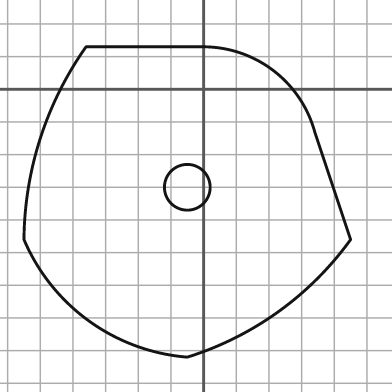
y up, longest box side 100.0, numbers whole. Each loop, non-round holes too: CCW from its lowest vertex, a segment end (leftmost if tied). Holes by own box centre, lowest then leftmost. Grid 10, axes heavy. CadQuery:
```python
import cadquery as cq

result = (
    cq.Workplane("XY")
    .moveTo(-5.0, -82.0)
    .threePointArc((23.0, -68.0), (45.0, -46.0))
    .lineTo(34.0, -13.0)
    .threePointArc((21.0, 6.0), (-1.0, 13.0))
    .lineTo(-36.0, 13.0)
    .threePointArc((-50.0, -15.0), (-55.0, -46.0))
    .threePointArc((-35.0, -71.0), (-5.0, -82.0))
    .close()
    .moveTo(-5.0, -30.0)
    .circle(7.0)
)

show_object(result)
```